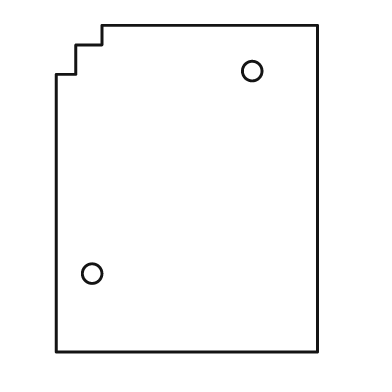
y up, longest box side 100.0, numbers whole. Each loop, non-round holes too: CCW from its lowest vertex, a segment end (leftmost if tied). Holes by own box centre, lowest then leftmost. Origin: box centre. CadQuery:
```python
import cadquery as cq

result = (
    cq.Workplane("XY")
    .moveTo(-40.0, -50.0)
    .lineTo(40.0, -50.0)
    .lineTo(40.0, 50.0)
    .lineTo(-26.0, 50.0)
    .lineTo(-26.0, 44.0)
    .lineTo(-34.0, 44.0)
    .lineTo(-34.0, 35.0)
    .lineTo(-40.0, 35.0)
    .close()
    .moveTo(-29.0, -26.0)
    .circle(3.0)
    .moveTo(20.0, 36.0)
    .circle(3.0)
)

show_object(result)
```